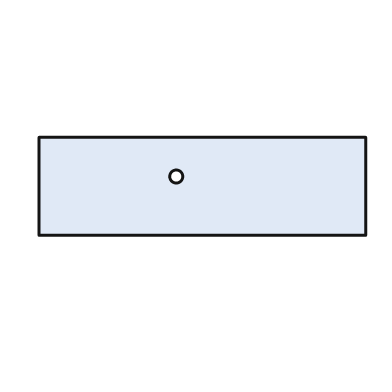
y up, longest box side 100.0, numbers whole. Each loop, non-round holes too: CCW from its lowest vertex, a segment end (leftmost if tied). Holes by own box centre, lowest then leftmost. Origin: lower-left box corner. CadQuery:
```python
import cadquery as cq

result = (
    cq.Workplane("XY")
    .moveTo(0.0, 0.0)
    .lineTo(100.0, 0.0)
    .lineTo(100.0, 30.0)
    .lineTo(0.0, 30.0)
    .close()
    .moveTo(42.0, 18.0)
    .circle(2.0)
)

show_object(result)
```